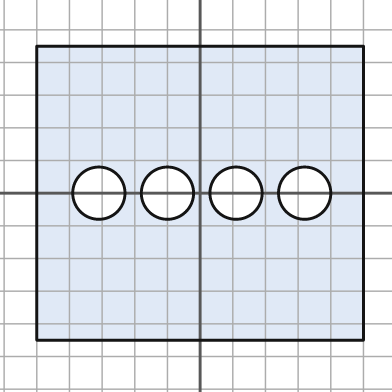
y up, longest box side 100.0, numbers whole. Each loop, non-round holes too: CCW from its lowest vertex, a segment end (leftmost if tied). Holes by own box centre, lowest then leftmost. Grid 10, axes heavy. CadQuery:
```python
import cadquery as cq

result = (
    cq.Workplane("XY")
    .moveTo(-50.0, -45.0)
    .lineTo(50.0, -45.0)
    .lineTo(50.0, 45.0)
    .lineTo(-50.0, 45.0)
    .close()
    .moveTo(-31.0, 0.0)
    .circle(8.0)
    .moveTo(-10.0, 0.0)
    .circle(8.0)
    .moveTo(11.0, 0.0)
    .circle(8.0)
    .moveTo(32.0, 0.0)
    .circle(8.0)
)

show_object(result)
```